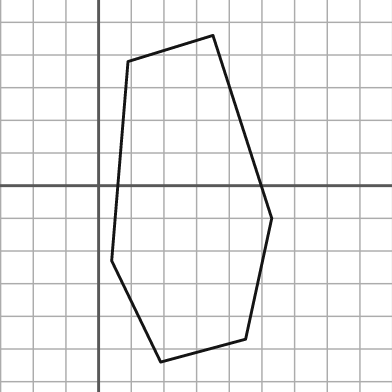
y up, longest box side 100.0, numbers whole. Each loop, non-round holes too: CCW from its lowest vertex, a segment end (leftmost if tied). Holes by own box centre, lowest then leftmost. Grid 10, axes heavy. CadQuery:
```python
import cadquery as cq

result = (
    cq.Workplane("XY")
    .moveTo(19.0, -54.0)
    .lineTo(45.0, -47.0)
    .lineTo(53.0, -10.0)
    .lineTo(35.0, 46.0)
    .lineTo(9.0, 38.0)
    .lineTo(4.0, -23.0)
    .close()
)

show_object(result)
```